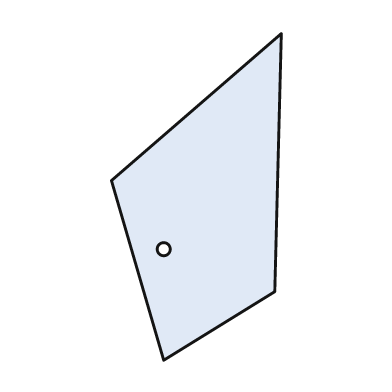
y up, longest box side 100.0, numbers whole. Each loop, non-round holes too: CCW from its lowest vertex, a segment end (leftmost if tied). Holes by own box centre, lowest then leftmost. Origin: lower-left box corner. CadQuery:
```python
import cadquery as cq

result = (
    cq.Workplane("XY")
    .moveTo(16.0, 0.0)
    .lineTo(50.0, 21.0)
    .lineTo(52.0, 100.0)
    .lineTo(0.0, 55.0)
    .close()
    .moveTo(16.0, 34.0)
    .circle(2.0)
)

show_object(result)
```